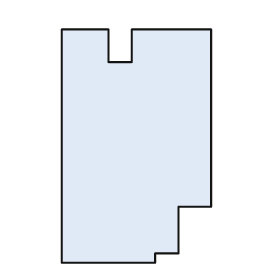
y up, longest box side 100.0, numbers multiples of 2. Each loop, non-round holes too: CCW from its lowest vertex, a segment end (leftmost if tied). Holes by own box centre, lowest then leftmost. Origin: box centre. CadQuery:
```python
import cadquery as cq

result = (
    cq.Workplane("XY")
    .moveTo(-32.0, -50.0)
    .lineTo(8.0, -50.0)
    .lineTo(8.0, -46.0)
    .lineTo(18.0, -46.0)
    .lineTo(18.0, -26.0)
    .lineTo(32.0, -26.0)
    .lineTo(32.0, 50.0)
    .lineTo(-2.0, 50.0)
    .lineTo(-2.0, 36.0)
    .lineTo(-12.0, 36.0)
    .lineTo(-12.0, 50.0)
    .lineTo(-32.0, 50.0)
    .close()
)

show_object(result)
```